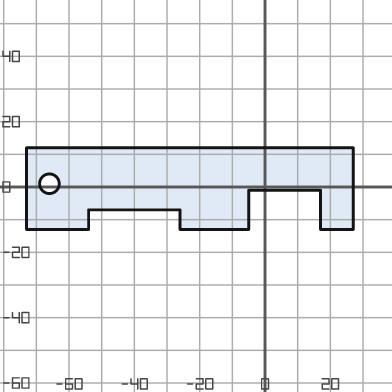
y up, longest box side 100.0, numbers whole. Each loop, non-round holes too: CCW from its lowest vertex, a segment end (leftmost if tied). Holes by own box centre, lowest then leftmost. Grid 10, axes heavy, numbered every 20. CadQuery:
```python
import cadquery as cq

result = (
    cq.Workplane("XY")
    .moveTo(-73.0, -13.0)
    .lineTo(-54.0, -13.0)
    .lineTo(-54.0, -7.0)
    .lineTo(-26.0, -7.0)
    .lineTo(-26.0, -13.0)
    .lineTo(-5.0, -13.0)
    .lineTo(-5.0, -1.0)
    .lineTo(17.0, -1.0)
    .lineTo(17.0, -13.0)
    .lineTo(27.0, -13.0)
    .lineTo(27.0, 12.0)
    .lineTo(-73.0, 12.0)
    .close()
    .moveTo(-66.0, 1.0)
    .circle(3.0)
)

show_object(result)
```